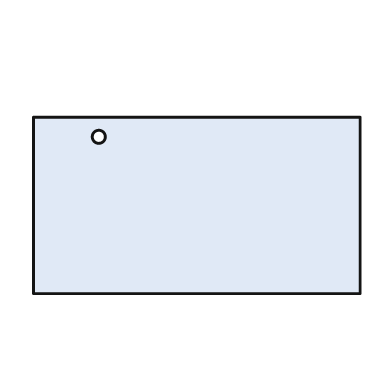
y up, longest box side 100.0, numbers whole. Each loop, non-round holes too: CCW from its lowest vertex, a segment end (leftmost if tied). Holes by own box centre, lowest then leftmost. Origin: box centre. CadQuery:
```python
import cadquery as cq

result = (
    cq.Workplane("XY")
    .moveTo(-50.0, -27.0)
    .lineTo(50.0, -27.0)
    .lineTo(50.0, 27.0)
    .lineTo(-50.0, 27.0)
    .close()
    .moveTo(-30.0, 21.0)
    .circle(2.0)
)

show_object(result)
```